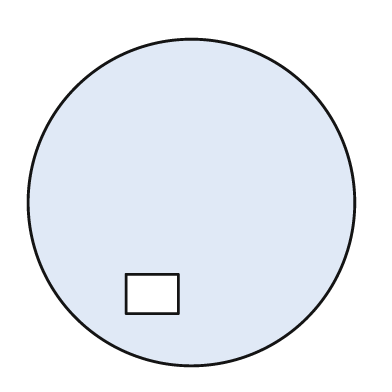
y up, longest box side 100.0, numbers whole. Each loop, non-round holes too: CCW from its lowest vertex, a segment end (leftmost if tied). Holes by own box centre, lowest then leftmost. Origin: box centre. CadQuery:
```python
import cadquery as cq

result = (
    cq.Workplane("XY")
    .moveTo(0.0, 0.0)
    .circle(50.0)
    .moveTo(-20.0, -34.0)
    .lineTo(-4.0, -34.0)
    .lineTo(-4.0, -22.0)
    .lineTo(-20.0, -22.0)
    .close()
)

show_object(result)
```